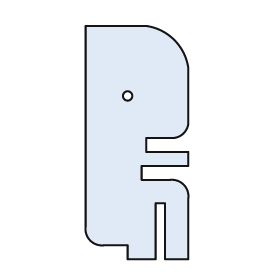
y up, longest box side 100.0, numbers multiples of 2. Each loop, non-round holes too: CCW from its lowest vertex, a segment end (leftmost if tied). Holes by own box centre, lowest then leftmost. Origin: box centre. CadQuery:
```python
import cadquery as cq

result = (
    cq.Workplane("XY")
    .moveTo(-4.0, -50.0)
    .lineTo(8.0, -50.0)
    .lineTo(8.0, -26.0)
    .lineTo(12.0, -26.0)
    .lineTo(12.0, -50.0)
    .lineTo(22.0, -50.0)
    .lineTo(22.0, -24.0)
    .threePointArc((20.0, -18.0), (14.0, -16.0))
    .lineTo(2.0, -16.0)
    .lineTo(2.0, -10.0)
    .lineTo(22.0, -10.0)
    .lineTo(22.0, -4.0)
    .lineTo(4.0, -4.0)
    .lineTo(4.0, 2.0)
    .lineTo(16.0, 2.0)
    .threePointArc((20.0, 4.0), (22.0, 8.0))
    .lineTo(22.0, 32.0)
    .threePointArc((16.0, 44.0), (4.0, 50.0))
    .lineTo(-22.0, 50.0)
    .lineTo(-22.0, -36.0)
    .threePointArc((-20.0, -42.0), (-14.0, -44.0))
    .lineTo(-4.0, -44.0)
    .close()
    .moveTo(-4.0, 20.0)
    .circle(2.0)
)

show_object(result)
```